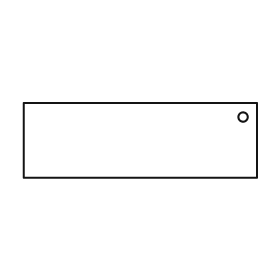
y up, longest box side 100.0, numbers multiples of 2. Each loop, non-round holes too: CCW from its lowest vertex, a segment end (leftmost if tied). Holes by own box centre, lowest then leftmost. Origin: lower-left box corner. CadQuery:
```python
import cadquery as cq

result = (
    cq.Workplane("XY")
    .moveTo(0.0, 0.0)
    .lineTo(100.0, 0.0)
    .lineTo(100.0, 32.0)
    .lineTo(0.0, 32.0)
    .close()
    .moveTo(94.0, 26.0)
    .circle(2.0)
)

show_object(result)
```